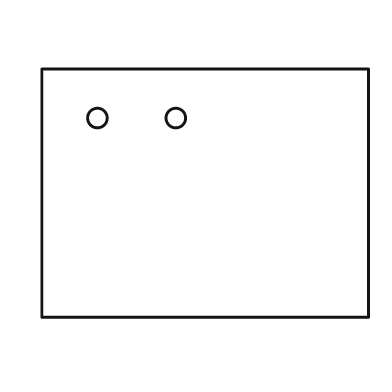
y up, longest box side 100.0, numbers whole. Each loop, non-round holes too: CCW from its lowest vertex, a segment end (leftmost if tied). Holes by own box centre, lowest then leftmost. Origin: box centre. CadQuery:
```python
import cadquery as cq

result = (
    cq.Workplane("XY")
    .moveTo(-50.0, -38.0)
    .lineTo(50.0, -38.0)
    .lineTo(50.0, 38.0)
    .lineTo(-50.0, 38.0)
    .close()
    .moveTo(-33.0, 23.0)
    .circle(3.0)
    .moveTo(-9.0, 23.0)
    .circle(3.0)
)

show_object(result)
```